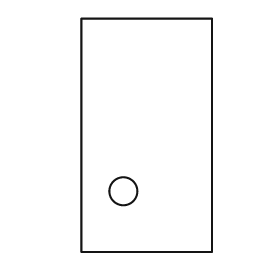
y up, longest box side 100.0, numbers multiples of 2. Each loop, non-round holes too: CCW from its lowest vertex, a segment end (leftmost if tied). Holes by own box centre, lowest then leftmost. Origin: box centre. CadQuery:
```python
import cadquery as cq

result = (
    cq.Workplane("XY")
    .moveTo(-28.0, -50.0)
    .lineTo(28.0, -50.0)
    .lineTo(28.0, 50.0)
    .lineTo(-28.0, 50.0)
    .close()
    .moveTo(-10.0, -24.0)
    .circle(6.0)
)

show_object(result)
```